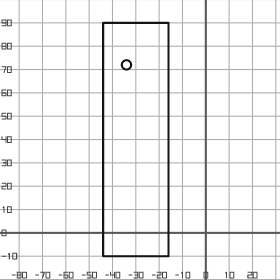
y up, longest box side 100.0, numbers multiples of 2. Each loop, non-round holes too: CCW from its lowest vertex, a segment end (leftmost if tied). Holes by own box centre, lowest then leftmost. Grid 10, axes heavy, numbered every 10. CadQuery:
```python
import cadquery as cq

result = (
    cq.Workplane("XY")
    .moveTo(-44.0, -10.0)
    .lineTo(-16.0, -10.0)
    .lineTo(-16.0, 90.0)
    .lineTo(-44.0, 90.0)
    .close()
    .moveTo(-34.0, 72.0)
    .circle(2.0)
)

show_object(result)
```